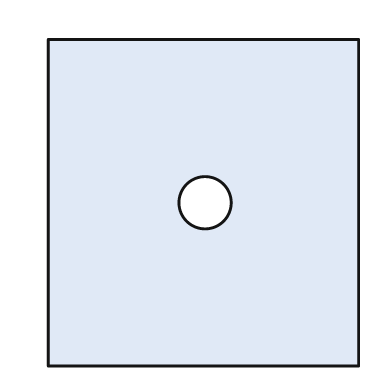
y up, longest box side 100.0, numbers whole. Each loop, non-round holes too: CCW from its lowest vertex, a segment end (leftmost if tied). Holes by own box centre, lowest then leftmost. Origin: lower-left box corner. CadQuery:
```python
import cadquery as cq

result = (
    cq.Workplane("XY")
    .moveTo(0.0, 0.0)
    .lineTo(95.0, 0.0)
    .lineTo(95.0, 100.0)
    .lineTo(0.0, 100.0)
    .close()
    .moveTo(48.0, 50.0)
    .circle(8.0)
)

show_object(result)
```